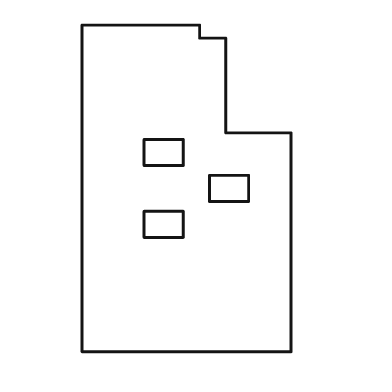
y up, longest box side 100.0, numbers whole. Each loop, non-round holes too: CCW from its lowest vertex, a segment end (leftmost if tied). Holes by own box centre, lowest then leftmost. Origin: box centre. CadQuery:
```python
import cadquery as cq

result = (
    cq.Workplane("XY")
    .moveTo(-32.0, -50.0)
    .lineTo(32.0, -50.0)
    .lineTo(32.0, 17.0)
    .lineTo(12.0, 17.0)
    .lineTo(12.0, 46.0)
    .lineTo(4.0, 46.0)
    .lineTo(4.0, 50.0)
    .lineTo(-32.0, 50.0)
    .close()
    .moveTo(-13.0, -15.0)
    .lineTo(-1.0, -15.0)
    .lineTo(-1.0, -7.0)
    .lineTo(-13.0, -7.0)
    .close()
    .moveTo(7.0, -4.0)
    .lineTo(19.0, -4.0)
    .lineTo(19.0, 4.0)
    .lineTo(7.0, 4.0)
    .close()
    .moveTo(-13.0, 7.0)
    .lineTo(-1.0, 7.0)
    .lineTo(-1.0, 15.0)
    .lineTo(-13.0, 15.0)
    .close()
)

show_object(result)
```